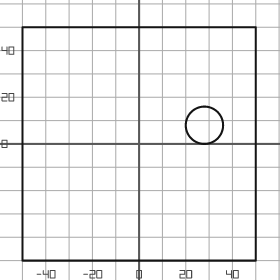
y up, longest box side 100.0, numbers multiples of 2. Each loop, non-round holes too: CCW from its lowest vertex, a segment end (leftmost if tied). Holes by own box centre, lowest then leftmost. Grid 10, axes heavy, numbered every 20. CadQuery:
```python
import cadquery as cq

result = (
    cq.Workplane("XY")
    .moveTo(-50.0, -50.0)
    .lineTo(50.0, -50.0)
    .lineTo(50.0, 50.0)
    .lineTo(-50.0, 50.0)
    .close()
    .moveTo(28.0, 8.0)
    .circle(8.0)
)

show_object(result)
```